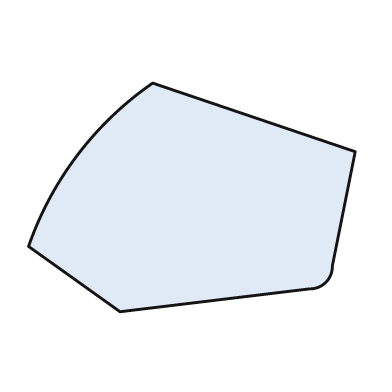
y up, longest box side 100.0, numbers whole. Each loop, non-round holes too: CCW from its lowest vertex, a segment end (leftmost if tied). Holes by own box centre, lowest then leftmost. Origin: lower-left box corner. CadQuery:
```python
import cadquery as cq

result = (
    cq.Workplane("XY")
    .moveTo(28.0, 0.0)
    .lineTo(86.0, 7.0)
    .threePointArc((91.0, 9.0), (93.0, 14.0))
    .lineTo(100.0, 49.0)
    .lineTo(38.0, 70.0)
    .threePointArc((15.0, 48.0), (0.0, 20.0))
    .close()
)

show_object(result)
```